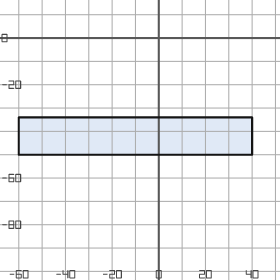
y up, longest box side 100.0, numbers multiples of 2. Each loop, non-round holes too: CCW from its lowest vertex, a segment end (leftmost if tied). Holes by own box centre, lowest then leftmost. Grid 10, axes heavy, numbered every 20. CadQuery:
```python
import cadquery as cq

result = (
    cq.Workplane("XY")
    .moveTo(-60.0, -50.0)
    .lineTo(40.0, -50.0)
    .lineTo(40.0, -34.0)
    .lineTo(-60.0, -34.0)
    .close()
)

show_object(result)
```